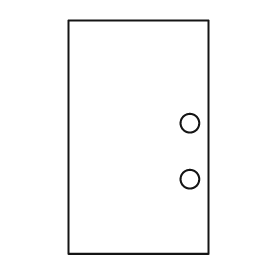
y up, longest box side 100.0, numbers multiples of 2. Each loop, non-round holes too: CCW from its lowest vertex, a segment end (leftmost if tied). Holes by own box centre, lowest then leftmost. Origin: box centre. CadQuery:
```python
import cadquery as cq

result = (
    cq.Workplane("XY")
    .moveTo(-30.0, -50.0)
    .lineTo(30.0, -50.0)
    .lineTo(30.0, 50.0)
    .lineTo(-30.0, 50.0)
    .close()
    .moveTo(22.0, -18.0)
    .circle(4.0)
    .moveTo(22.0, 6.0)
    .circle(4.0)
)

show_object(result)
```